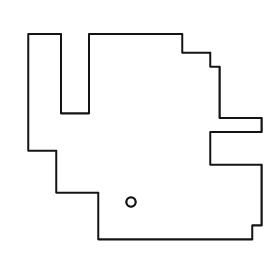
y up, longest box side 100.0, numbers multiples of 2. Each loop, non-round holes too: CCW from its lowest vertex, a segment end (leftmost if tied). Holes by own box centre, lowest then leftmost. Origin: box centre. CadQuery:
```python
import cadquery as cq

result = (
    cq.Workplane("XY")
    .moveTo(-20.0, -44.0)
    .lineTo(46.0, -44.0)
    .lineTo(46.0, -38.0)
    .lineTo(50.0, -38.0)
    .lineTo(50.0, -12.0)
    .lineTo(28.0, -12.0)
    .lineTo(28.0, 2.0)
    .lineTo(50.0, 2.0)
    .lineTo(50.0, 8.0)
    .lineTo(32.0, 8.0)
    .lineTo(32.0, 30.0)
    .lineTo(28.0, 30.0)
    .lineTo(28.0, 36.0)
    .lineTo(16.0, 36.0)
    .lineTo(16.0, 44.0)
    .lineTo(-24.0, 44.0)
    .lineTo(-24.0, 10.0)
    .lineTo(-36.0, 10.0)
    .lineTo(-36.0, 44.0)
    .lineTo(-50.0, 44.0)
    .lineTo(-50.0, -6.0)
    .lineTo(-38.0, -6.0)
    .lineTo(-38.0, -24.0)
    .lineTo(-20.0, -24.0)
    .close()
    .moveTo(-6.0, -28.0)
    .circle(2.0)
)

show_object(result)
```